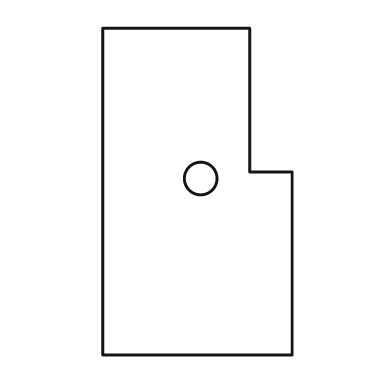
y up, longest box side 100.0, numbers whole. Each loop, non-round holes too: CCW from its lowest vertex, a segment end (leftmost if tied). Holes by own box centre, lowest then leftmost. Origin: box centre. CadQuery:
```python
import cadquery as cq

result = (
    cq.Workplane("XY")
    .moveTo(-29.0, -50.0)
    .lineTo(29.0, -50.0)
    .lineTo(29.0, 6.0)
    .lineTo(16.0, 6.0)
    .lineTo(16.0, 50.0)
    .lineTo(-29.0, 50.0)
    .close()
    .moveTo(1.0, 4.0)
    .circle(5.0)
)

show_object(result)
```